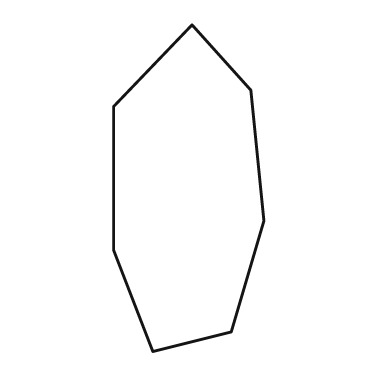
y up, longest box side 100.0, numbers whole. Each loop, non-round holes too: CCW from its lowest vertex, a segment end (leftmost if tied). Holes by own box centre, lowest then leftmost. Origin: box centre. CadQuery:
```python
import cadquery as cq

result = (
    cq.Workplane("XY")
    .moveTo(-11.0, -50.0)
    .lineTo(13.0, -44.0)
    .lineTo(23.0, -10.0)
    .lineTo(19.0, 30.0)
    .lineTo(1.0, 50.0)
    .lineTo(-23.0, 25.0)
    .lineTo(-23.0, -19.0)
    .close()
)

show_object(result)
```